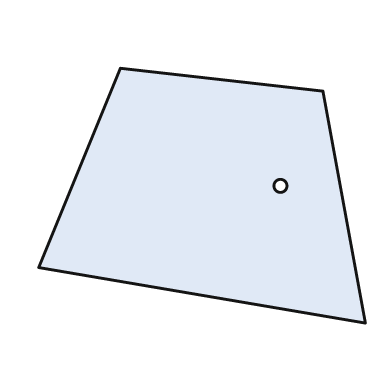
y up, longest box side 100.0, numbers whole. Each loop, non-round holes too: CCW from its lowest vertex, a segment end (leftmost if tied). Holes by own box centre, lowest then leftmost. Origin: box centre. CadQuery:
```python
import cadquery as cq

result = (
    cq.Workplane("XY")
    .moveTo(50.0, -39.0)
    .lineTo(37.0, 32.0)
    .lineTo(-25.0, 39.0)
    .lineTo(-50.0, -22.0)
    .close()
    .moveTo(24.0, 3.0)
    .circle(2.0)
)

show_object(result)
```